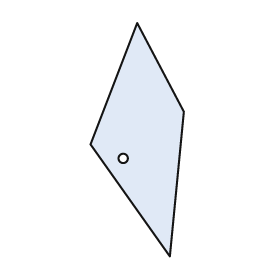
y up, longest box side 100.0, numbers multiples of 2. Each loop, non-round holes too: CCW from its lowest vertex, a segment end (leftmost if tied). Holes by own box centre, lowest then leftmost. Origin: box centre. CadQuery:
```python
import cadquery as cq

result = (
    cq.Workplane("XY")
    .moveTo(14.0, -50.0)
    .lineTo(20.0, 12.0)
    .lineTo(0.0, 50.0)
    .lineTo(-20.0, -2.0)
    .close()
    .moveTo(-6.0, -8.0)
    .circle(2.0)
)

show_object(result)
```